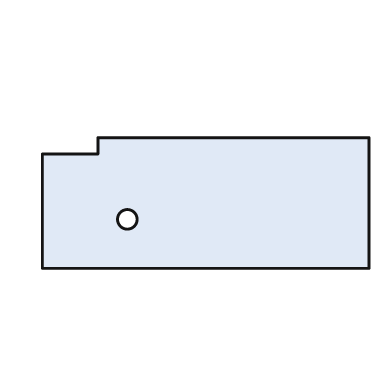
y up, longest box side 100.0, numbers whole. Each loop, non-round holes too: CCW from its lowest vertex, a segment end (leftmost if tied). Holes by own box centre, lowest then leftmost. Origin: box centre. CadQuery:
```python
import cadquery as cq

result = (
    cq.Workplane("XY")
    .moveTo(-50.0, -20.0)
    .lineTo(50.0, -20.0)
    .lineTo(50.0, 20.0)
    .lineTo(-33.0, 20.0)
    .lineTo(-33.0, 15.0)
    .lineTo(-50.0, 15.0)
    .close()
    .moveTo(-24.0, -5.0)
    .circle(3.0)
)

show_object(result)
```